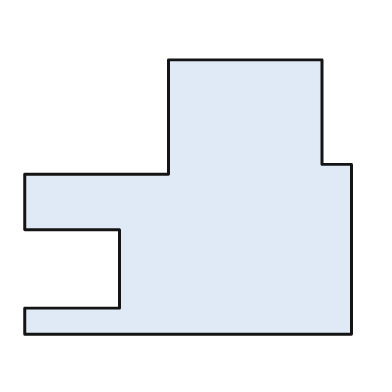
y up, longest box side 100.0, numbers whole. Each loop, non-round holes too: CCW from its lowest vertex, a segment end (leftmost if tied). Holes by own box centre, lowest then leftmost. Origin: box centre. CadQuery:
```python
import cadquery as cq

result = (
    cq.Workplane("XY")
    .moveTo(-50.0, -42.0)
    .lineTo(50.0, -42.0)
    .lineTo(50.0, 10.0)
    .lineTo(41.0, 10.0)
    .lineTo(41.0, 42.0)
    .lineTo(-6.0, 42.0)
    .lineTo(-6.0, 7.0)
    .lineTo(-50.0, 7.0)
    .lineTo(-50.0, -10.0)
    .lineTo(-21.0, -10.0)
    .lineTo(-21.0, -34.0)
    .lineTo(-50.0, -34.0)
    .close()
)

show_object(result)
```